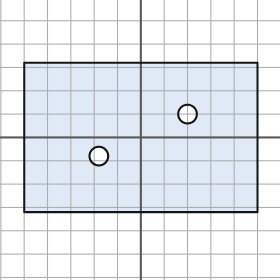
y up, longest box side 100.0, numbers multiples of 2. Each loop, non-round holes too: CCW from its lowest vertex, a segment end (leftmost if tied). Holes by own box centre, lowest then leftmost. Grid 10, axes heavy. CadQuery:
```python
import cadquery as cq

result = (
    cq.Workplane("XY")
    .moveTo(-50.0, -32.0)
    .lineTo(50.0, -32.0)
    .lineTo(50.0, 32.0)
    .lineTo(-50.0, 32.0)
    .close()
    .moveTo(-18.0, -8.0)
    .circle(4.0)
    .moveTo(20.0, 10.0)
    .circle(4.0)
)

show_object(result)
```